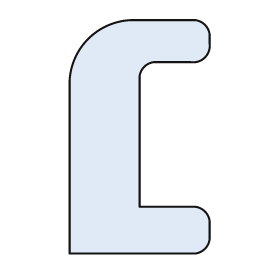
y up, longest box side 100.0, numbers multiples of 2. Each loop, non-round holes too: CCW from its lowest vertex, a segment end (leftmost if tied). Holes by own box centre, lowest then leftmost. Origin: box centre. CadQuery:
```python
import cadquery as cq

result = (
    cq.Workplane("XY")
    .moveTo(-30.0, -50.0)
    .lineTo(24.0, -50.0)
    .threePointArc((28.0, -48.0), (30.0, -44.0))
    .lineTo(30.0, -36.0)
    .threePointArc((28.0, -32.0), (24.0, -30.0))
    .lineTo(0.0, -30.0)
    .lineTo(0.0, 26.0)
    .threePointArc((2.0, 30.0), (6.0, 32.0))
    .lineTo(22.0, 32.0)
    .threePointArc((28.0, 34.0), (30.0, 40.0))
    .lineTo(30.0, 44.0)
    .threePointArc((28.0, 48.0), (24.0, 50.0))
    .lineTo(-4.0, 50.0)
    .threePointArc((-22.0, 42.0), (-30.0, 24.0))
    .close()
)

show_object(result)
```